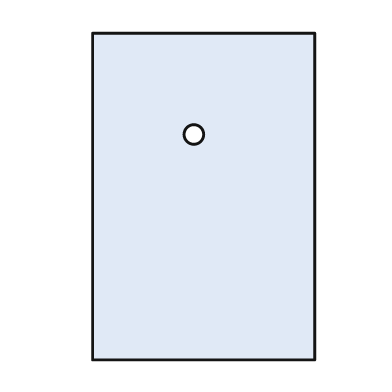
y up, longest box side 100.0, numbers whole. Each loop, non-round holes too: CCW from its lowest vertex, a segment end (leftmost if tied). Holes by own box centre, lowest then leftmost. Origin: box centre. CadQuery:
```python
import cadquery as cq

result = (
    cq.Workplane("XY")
    .moveTo(-34.0, -50.0)
    .lineTo(34.0, -50.0)
    .lineTo(34.0, 50.0)
    .lineTo(-34.0, 50.0)
    .close()
    .moveTo(-3.0, 19.0)
    .circle(3.0)
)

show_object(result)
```